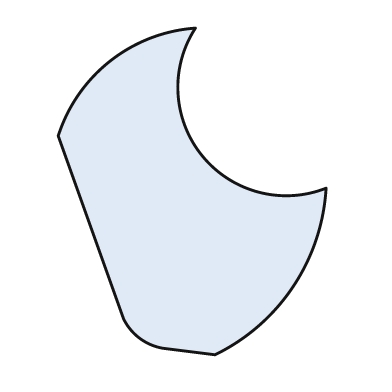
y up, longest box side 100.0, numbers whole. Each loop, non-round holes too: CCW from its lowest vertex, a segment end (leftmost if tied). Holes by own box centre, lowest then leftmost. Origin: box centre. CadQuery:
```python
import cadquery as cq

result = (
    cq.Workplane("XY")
    .moveTo(7.0, -50.0)
    .threePointArc((31.0, -29.0), (41.0, 1.0))
    .threePointArc((3.0, 11.0), (1.0, 50.0))
    .threePointArc((-25.0, 40.0), (-41.0, 17.0))
    .lineTo(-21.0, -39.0)
    .threePointArc((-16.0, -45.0), (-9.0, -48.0))
    .close()
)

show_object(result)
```